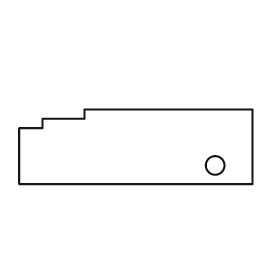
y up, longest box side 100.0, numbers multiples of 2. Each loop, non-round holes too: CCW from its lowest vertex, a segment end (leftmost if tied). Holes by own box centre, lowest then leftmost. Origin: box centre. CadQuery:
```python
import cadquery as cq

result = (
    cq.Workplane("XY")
    .moveTo(-50.0, -16.0)
    .lineTo(50.0, -16.0)
    .lineTo(50.0, 16.0)
    .lineTo(-22.0, 16.0)
    .lineTo(-22.0, 12.0)
    .lineTo(-40.0, 12.0)
    .lineTo(-40.0, 8.0)
    .lineTo(-50.0, 8.0)
    .close()
    .moveTo(34.0, -8.0)
    .circle(4.0)
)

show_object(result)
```